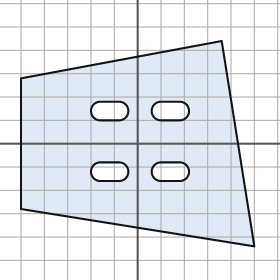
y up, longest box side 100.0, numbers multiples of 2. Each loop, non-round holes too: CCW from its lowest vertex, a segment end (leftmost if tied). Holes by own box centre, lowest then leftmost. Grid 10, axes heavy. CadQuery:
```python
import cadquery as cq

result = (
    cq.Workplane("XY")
    .moveTo(50.0, -44.0)
    .lineTo(36.0, 44.0)
    .lineTo(-50.0, 28.0)
    .lineTo(-50.0, -28.0)
    .close()
    .moveTo(-16.0, -16.0)
    .lineTo(-8.0, -16.0)
    .threePointArc((-4.0, -12.0), (-8.0, -8.0))
    .lineTo(-16.0, -8.0)
    .threePointArc((-20.0, -12.0), (-16.0, -16.0))
    .close()
    .moveTo(10.0, -16.0)
    .lineTo(18.0, -16.0)
    .threePointArc((22.0, -12.0), (18.0, -8.0))
    .lineTo(10.0, -8.0)
    .threePointArc((6.0, -12.0), (10.0, -16.0))
    .close()
    .moveTo(-16.0, 10.0)
    .lineTo(-8.0, 10.0)
    .threePointArc((-4.0, 14.0), (-8.0, 18.0))
    .lineTo(-16.0, 18.0)
    .threePointArc((-20.0, 14.0), (-16.0, 10.0))
    .close()
    .moveTo(10.0, 10.0)
    .lineTo(18.0, 10.0)
    .threePointArc((22.0, 14.0), (18.0, 18.0))
    .lineTo(10.0, 18.0)
    .threePointArc((6.0, 14.0), (10.0, 10.0))
    .close()
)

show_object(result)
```